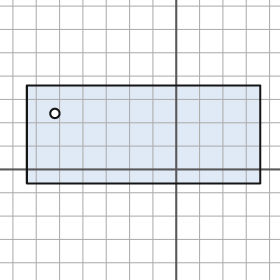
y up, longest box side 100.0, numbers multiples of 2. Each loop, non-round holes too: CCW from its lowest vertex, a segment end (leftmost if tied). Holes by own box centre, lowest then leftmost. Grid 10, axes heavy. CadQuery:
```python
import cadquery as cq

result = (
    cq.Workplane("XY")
    .moveTo(-64.0, -6.0)
    .lineTo(36.0, -6.0)
    .lineTo(36.0, 36.0)
    .lineTo(-64.0, 36.0)
    .close()
    .moveTo(-52.0, 24.0)
    .circle(2.0)
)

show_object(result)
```